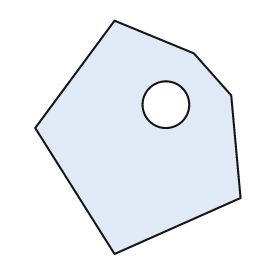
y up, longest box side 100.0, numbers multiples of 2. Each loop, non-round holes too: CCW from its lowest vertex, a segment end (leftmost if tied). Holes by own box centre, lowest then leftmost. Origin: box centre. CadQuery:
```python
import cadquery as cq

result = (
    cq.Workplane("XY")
    .moveTo(-10.0, -50.0)
    .lineTo(44.0, -26.0)
    .lineTo(40.0, 18.0)
    .lineTo(24.0, 36.0)
    .lineTo(-10.0, 50.0)
    .lineTo(-44.0, 4.0)
    .close()
    .moveTo(12.0, 14.0)
    .circle(10.0)
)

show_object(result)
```